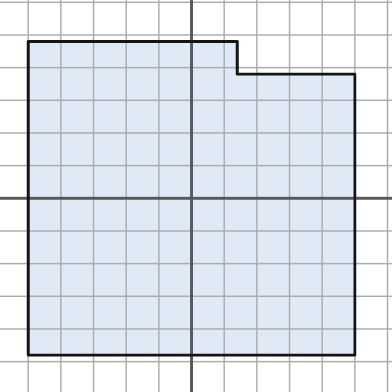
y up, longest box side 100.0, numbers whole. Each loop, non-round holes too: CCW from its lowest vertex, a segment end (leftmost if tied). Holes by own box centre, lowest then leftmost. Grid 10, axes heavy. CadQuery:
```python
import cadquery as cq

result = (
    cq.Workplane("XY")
    .moveTo(-50.0, -48.0)
    .lineTo(50.0, -48.0)
    .lineTo(50.0, 38.0)
    .lineTo(14.0, 38.0)
    .lineTo(14.0, 48.0)
    .lineTo(-50.0, 48.0)
    .close()
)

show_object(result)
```